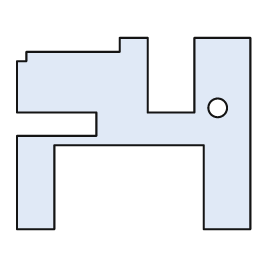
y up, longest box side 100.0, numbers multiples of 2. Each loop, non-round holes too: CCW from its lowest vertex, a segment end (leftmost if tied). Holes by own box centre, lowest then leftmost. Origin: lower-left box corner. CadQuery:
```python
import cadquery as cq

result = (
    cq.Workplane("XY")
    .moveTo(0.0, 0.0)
    .lineTo(16.0, 0.0)
    .lineTo(16.0, 36.0)
    .lineTo(80.0, 36.0)
    .lineTo(80.0, 0.0)
    .lineTo(100.0, 0.0)
    .lineTo(100.0, 82.0)
    .lineTo(76.0, 82.0)
    .lineTo(76.0, 50.0)
    .lineTo(56.0, 50.0)
    .lineTo(56.0, 82.0)
    .lineTo(44.0, 82.0)
    .lineTo(44.0, 76.0)
    .lineTo(4.0, 76.0)
    .lineTo(4.0, 72.0)
    .lineTo(0.0, 72.0)
    .lineTo(0.0, 50.0)
    .lineTo(34.0, 50.0)
    .lineTo(34.0, 40.0)
    .lineTo(0.0, 40.0)
    .close()
    .moveTo(86.0, 52.0)
    .circle(4.0)
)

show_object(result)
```